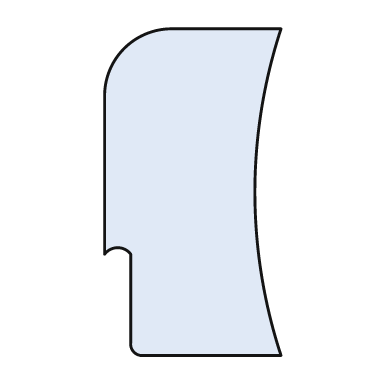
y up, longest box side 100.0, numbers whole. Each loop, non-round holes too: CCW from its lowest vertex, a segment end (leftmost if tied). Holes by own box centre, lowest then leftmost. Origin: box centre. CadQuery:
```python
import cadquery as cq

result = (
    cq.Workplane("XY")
    .moveTo(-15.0, -50.0)
    .lineTo(27.0, -50.0)
    .threePointArc((19.0, 0.0), (27.0, 50.0))
    .lineTo(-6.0, 50.0)
    .threePointArc((-21.0, 44.0), (-27.0, 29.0))
    .lineTo(-27.0, -19.0)
    .threePointArc((-23.0, -17.0), (-19.0, -19.0))
    .lineTo(-19.0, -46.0)
    .threePointArc((-18.0, -49.0), (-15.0, -50.0))
    .close()
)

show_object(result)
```